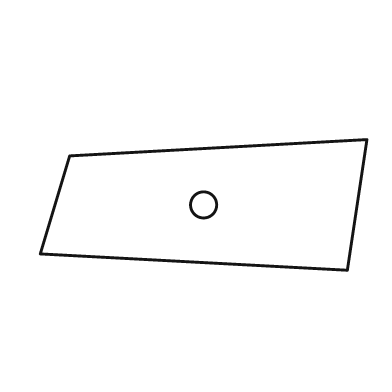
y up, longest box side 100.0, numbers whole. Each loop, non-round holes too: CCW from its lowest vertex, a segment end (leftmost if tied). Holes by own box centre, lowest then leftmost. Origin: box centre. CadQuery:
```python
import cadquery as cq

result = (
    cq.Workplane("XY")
    .moveTo(44.0, -20.0)
    .lineTo(50.0, 20.0)
    .lineTo(-41.0, 15.0)
    .lineTo(-50.0, -15.0)
    .close()
    .moveTo(0.0, 0.0)
    .circle(4.0)
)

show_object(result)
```